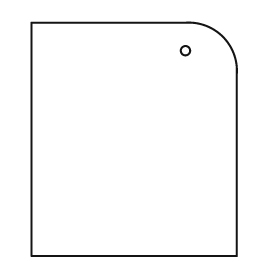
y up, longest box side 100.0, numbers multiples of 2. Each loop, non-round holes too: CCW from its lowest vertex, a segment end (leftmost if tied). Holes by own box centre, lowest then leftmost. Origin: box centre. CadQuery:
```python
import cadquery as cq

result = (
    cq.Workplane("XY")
    .moveTo(-44.0, -50.0)
    .lineTo(44.0, -50.0)
    .lineTo(44.0, 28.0)
    .threePointArc((38.0, 44.0), (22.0, 50.0))
    .lineTo(-44.0, 50.0)
    .close()
    .moveTo(22.0, 38.0)
    .circle(2.0)
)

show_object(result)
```